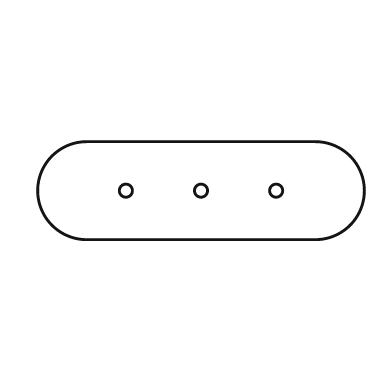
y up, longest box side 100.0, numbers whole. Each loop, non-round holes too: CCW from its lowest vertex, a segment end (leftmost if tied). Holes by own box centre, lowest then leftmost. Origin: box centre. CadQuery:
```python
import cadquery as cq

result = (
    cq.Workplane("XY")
    .moveTo(-35.0, -15.0)
    .lineTo(35.0, -15.0)
    .threePointArc((50.0, 0.0), (35.0, 15.0))
    .lineTo(-35.0, 15.0)
    .threePointArc((-50.0, 0.0), (-35.0, -15.0))
    .close()
    .moveTo(-23.0, 0.0)
    .circle(2.0)
    .moveTo(0.0, 0.0)
    .circle(2.0)
    .moveTo(23.0, 0.0)
    .circle(2.0)
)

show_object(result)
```